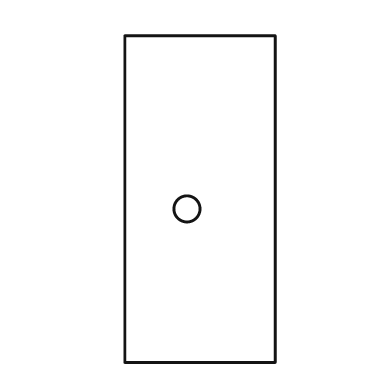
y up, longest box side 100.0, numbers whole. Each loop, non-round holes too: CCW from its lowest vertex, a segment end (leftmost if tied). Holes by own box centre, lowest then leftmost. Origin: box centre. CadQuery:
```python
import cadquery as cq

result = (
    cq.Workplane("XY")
    .moveTo(-23.0, -50.0)
    .lineTo(23.0, -50.0)
    .lineTo(23.0, 50.0)
    .lineTo(-23.0, 50.0)
    .close()
    .moveTo(-4.0, -3.0)
    .circle(4.0)
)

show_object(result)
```